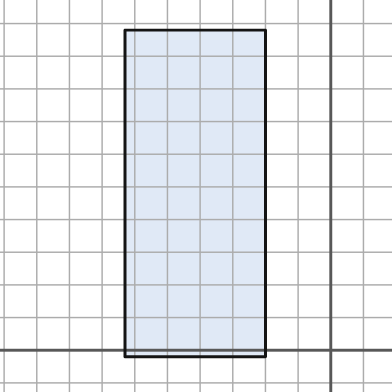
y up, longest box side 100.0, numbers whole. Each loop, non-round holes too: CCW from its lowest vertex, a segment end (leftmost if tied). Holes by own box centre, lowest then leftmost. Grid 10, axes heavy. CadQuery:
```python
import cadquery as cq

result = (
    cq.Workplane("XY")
    .moveTo(-63.0, -2.0)
    .lineTo(-20.0, -2.0)
    .lineTo(-20.0, 98.0)
    .lineTo(-63.0, 98.0)
    .close()
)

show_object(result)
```